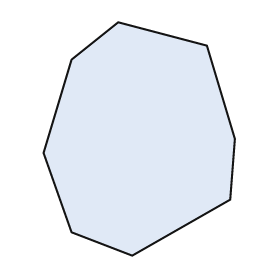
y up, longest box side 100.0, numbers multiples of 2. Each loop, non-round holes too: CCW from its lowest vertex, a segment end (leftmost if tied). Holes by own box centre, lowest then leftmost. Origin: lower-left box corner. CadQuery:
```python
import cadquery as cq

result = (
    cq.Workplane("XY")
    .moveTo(38.0, 0.0)
    .lineTo(80.0, 24.0)
    .lineTo(82.0, 50.0)
    .lineTo(70.0, 90.0)
    .lineTo(32.0, 100.0)
    .lineTo(12.0, 84.0)
    .lineTo(0.0, 44.0)
    .lineTo(12.0, 10.0)
    .close()
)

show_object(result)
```